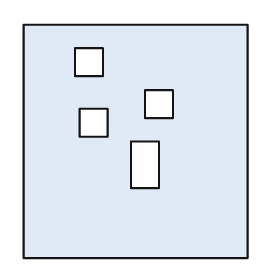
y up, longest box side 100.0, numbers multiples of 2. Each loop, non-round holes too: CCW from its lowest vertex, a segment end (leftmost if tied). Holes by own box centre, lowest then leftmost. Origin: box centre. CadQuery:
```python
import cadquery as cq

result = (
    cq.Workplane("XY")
    .moveTo(-48.0, -50.0)
    .lineTo(48.0, -50.0)
    .lineTo(48.0, 50.0)
    .lineTo(-48.0, 50.0)
    .close()
    .moveTo(-2.0, -20.0)
    .lineTo(10.0, -20.0)
    .lineTo(10.0, 0.0)
    .lineTo(-2.0, 0.0)
    .close()
    .moveTo(-24.0, 2.0)
    .lineTo(-12.0, 2.0)
    .lineTo(-12.0, 14.0)
    .lineTo(-24.0, 14.0)
    .close()
    .moveTo(4.0, 10.0)
    .lineTo(16.0, 10.0)
    .lineTo(16.0, 22.0)
    .lineTo(4.0, 22.0)
    .close()
    .moveTo(-26.0, 28.0)
    .lineTo(-14.0, 28.0)
    .lineTo(-14.0, 40.0)
    .lineTo(-26.0, 40.0)
    .close()
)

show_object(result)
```